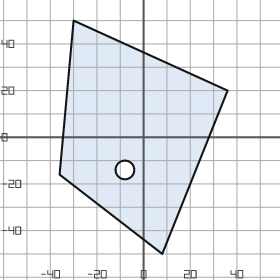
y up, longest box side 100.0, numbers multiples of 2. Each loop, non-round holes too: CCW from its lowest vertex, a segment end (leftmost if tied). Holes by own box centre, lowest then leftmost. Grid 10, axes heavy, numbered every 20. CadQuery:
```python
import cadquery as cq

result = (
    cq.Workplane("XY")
    .moveTo(8.0, -50.0)
    .lineTo(36.0, 20.0)
    .lineTo(-30.0, 50.0)
    .lineTo(-36.0, -16.0)
    .close()
    .moveTo(-8.0, -14.0)
    .circle(4.0)
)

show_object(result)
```